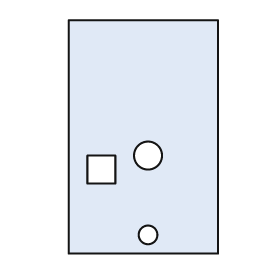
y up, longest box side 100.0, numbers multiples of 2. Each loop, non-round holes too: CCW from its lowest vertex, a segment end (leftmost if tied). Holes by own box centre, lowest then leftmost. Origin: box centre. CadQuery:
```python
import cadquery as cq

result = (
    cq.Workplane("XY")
    .moveTo(-32.0, -50.0)
    .lineTo(32.0, -50.0)
    .lineTo(32.0, 50.0)
    .lineTo(-32.0, 50.0)
    .close()
    .moveTo(2.0, -42.0)
    .circle(4.0)
    .moveTo(-24.0, -20.0)
    .lineTo(-12.0, -20.0)
    .lineTo(-12.0, -8.0)
    .lineTo(-24.0, -8.0)
    .close()
    .moveTo(2.0, -8.0)
    .circle(6.0)
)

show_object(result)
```